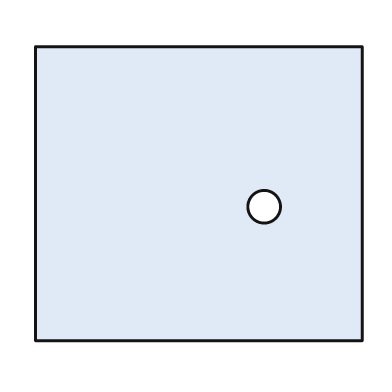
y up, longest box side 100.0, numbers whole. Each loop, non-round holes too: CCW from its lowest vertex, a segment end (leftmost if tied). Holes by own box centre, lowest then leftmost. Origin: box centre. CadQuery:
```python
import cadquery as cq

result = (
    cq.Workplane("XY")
    .moveTo(-50.0, -45.0)
    .lineTo(50.0, -45.0)
    .lineTo(50.0, 45.0)
    .lineTo(-50.0, 45.0)
    .close()
    .moveTo(20.0, -4.0)
    .circle(5.0)
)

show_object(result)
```